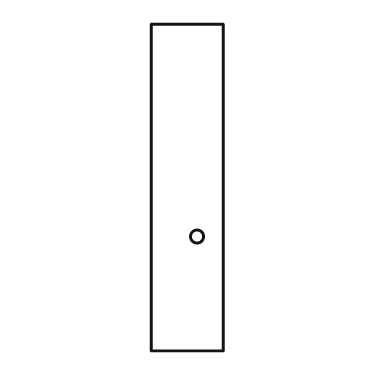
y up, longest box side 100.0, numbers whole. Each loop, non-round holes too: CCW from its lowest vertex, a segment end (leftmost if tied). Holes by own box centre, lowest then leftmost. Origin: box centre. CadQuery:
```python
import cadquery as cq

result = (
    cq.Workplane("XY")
    .moveTo(-11.0, -50.0)
    .lineTo(11.0, -50.0)
    .lineTo(11.0, 50.0)
    .lineTo(-11.0, 50.0)
    .close()
    .moveTo(3.0, -15.0)
    .circle(2.0)
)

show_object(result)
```